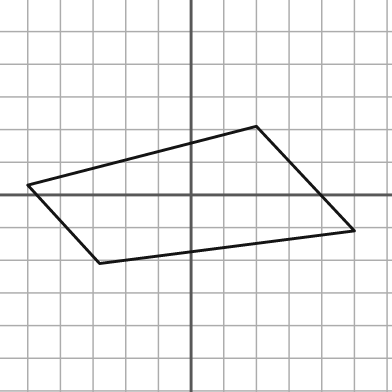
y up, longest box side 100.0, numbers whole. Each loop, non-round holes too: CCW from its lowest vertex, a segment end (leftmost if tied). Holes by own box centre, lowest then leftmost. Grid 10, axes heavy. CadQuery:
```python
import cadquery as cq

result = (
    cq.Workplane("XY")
    .moveTo(-28.0, -21.0)
    .lineTo(50.0, -11.0)
    .lineTo(20.0, 21.0)
    .lineTo(-50.0, 3.0)
    .close()
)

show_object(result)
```